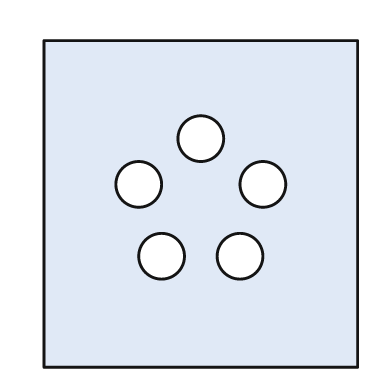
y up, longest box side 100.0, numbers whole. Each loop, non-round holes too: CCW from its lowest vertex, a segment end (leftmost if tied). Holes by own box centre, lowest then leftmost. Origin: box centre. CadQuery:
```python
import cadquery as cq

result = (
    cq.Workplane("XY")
    .moveTo(-48.0, -50.0)
    .lineTo(48.0, -50.0)
    .lineTo(48.0, 50.0)
    .lineTo(-48.0, 50.0)
    .close()
    .moveTo(-12.0, -16.0)
    .circle(7.0)
    .moveTo(12.0, -16.0)
    .circle(7.0)
    .moveTo(-19.0, 6.0)
    .circle(7.0)
    .moveTo(19.0, 6.0)
    .circle(7.0)
    .moveTo(0.0, 20.0)
    .circle(7.0)
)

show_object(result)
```